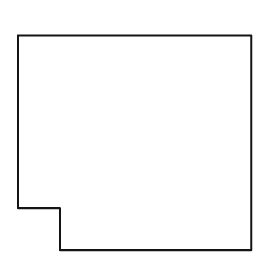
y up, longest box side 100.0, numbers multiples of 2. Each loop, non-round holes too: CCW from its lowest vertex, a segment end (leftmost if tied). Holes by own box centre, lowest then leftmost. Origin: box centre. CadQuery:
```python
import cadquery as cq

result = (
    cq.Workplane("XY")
    .moveTo(-32.0, -46.0)
    .lineTo(50.0, -46.0)
    .lineTo(50.0, 46.0)
    .lineTo(-50.0, 46.0)
    .lineTo(-50.0, -28.0)
    .lineTo(-32.0, -28.0)
    .close()
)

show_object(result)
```